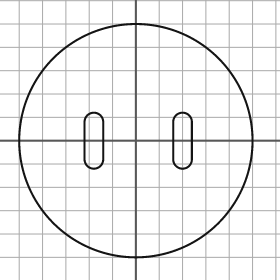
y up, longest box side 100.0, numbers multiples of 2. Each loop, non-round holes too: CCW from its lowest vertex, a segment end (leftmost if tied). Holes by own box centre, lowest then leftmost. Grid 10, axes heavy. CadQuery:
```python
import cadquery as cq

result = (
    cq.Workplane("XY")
    .moveTo(0.0, 0.0)
    .circle(50.0)
    .moveTo(-22.0, -8.0)
    .threePointArc((-18.0, -12.0), (-14.0, -8.0))
    .lineTo(-14.0, 8.0)
    .threePointArc((-18.0, 12.0), (-22.0, 8.0))
    .close()
    .moveTo(16.0, -8.0)
    .threePointArc((20.0, -12.0), (24.0, -8.0))
    .lineTo(24.0, 8.0)
    .threePointArc((20.0, 12.0), (16.0, 8.0))
    .close()
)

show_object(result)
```